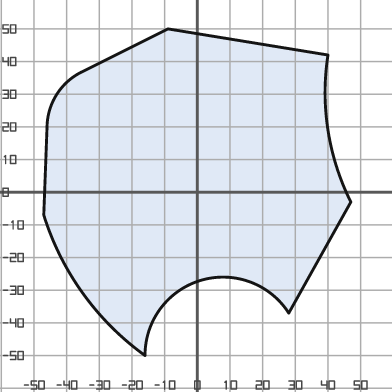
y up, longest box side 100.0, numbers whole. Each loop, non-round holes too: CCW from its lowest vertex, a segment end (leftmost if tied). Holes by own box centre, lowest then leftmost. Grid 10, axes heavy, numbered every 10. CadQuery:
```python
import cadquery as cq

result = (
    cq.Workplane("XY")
    .moveTo(-16.0, -50.0)
    .threePointArc((1.0, -27.0), (28.0, -37.0))
    .lineTo(47.0, -3.0)
    .threePointArc((40.0, 19.0), (40.0, 42.0))
    .lineTo(-9.0, 50.0)
    .lineTo(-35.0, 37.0)
    .threePointArc((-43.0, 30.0), (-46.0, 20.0))
    .lineTo(-47.0, -7.0)
    .threePointArc((-35.0, -31.0), (-16.0, -50.0))
    .close()
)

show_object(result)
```